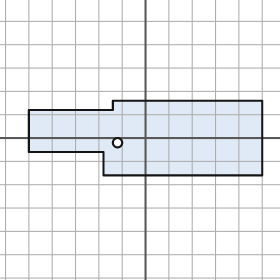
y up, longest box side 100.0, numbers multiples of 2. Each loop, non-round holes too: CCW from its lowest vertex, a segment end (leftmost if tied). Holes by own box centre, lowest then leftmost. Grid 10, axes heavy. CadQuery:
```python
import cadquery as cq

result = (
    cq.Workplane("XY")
    .moveTo(-18.0, -16.0)
    .lineTo(50.0, -16.0)
    .lineTo(50.0, 16.0)
    .lineTo(-14.0, 16.0)
    .lineTo(-14.0, 12.0)
    .lineTo(-50.0, 12.0)
    .lineTo(-50.0, -6.0)
    .lineTo(-18.0, -6.0)
    .close()
    .moveTo(-12.0, -2.0)
    .circle(2.0)
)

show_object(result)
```